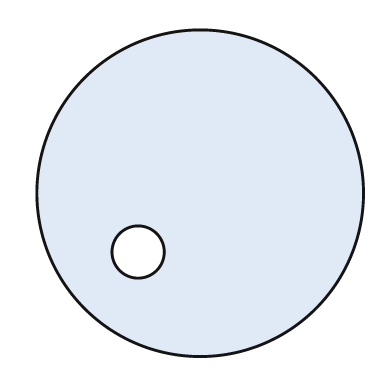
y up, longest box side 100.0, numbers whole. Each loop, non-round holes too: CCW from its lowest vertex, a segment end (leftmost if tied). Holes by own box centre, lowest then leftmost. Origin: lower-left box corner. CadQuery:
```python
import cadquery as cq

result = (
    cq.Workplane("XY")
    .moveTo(50.0, 50.0)
    .circle(50.0)
    .moveTo(31.0, 32.0)
    .circle(8.0)
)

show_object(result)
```